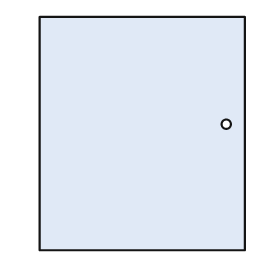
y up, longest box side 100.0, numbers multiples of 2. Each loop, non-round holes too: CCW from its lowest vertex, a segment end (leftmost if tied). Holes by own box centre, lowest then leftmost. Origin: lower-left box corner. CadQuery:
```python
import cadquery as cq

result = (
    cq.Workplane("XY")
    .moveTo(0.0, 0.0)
    .lineTo(88.0, 0.0)
    .lineTo(88.0, 100.0)
    .lineTo(0.0, 100.0)
    .close()
    .moveTo(80.0, 54.0)
    .circle(2.0)
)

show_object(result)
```